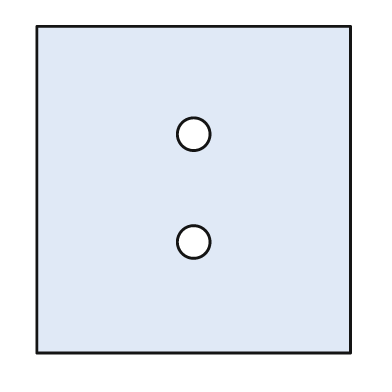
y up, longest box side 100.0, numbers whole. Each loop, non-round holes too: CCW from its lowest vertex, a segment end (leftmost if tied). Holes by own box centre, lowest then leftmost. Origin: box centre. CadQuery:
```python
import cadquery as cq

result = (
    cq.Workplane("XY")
    .moveTo(-48.0, -50.0)
    .lineTo(48.0, -50.0)
    .lineTo(48.0, 50.0)
    .lineTo(-48.0, 50.0)
    .close()
    .moveTo(0.0, -16.0)
    .circle(5.0)
    .moveTo(0.0, 17.0)
    .circle(5.0)
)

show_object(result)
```